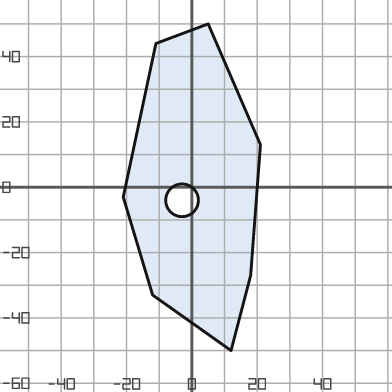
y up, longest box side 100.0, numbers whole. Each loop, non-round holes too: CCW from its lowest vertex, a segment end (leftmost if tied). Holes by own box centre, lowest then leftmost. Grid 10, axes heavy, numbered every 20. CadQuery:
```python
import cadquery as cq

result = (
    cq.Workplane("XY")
    .moveTo(12.0, -50.0)
    .lineTo(18.0, -27.0)
    .lineTo(21.0, 13.0)
    .lineTo(5.0, 50.0)
    .lineTo(-11.0, 44.0)
    .lineTo(-21.0, -3.0)
    .lineTo(-12.0, -33.0)
    .close()
    .moveTo(-3.0, -4.0)
    .circle(5.0)
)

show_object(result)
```